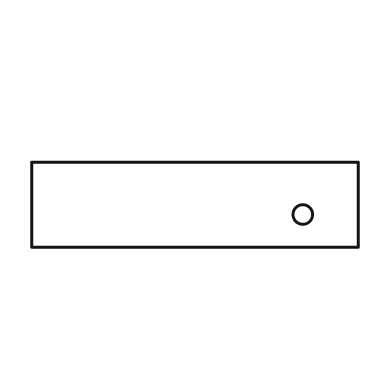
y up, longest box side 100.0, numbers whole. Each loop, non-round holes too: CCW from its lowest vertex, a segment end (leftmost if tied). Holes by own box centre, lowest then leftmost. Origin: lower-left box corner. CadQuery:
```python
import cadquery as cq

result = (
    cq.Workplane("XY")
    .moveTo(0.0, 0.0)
    .lineTo(100.0, 0.0)
    .lineTo(100.0, 26.0)
    .lineTo(0.0, 26.0)
    .close()
    .moveTo(83.0, 10.0)
    .circle(3.0)
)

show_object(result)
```